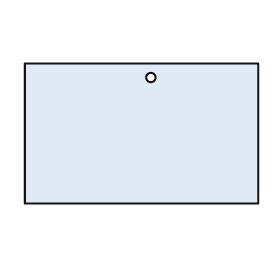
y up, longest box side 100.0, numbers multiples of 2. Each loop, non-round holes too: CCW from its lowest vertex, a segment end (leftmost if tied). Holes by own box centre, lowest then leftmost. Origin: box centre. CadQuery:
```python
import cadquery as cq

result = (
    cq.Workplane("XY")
    .moveTo(-50.0, -30.0)
    .lineTo(50.0, -30.0)
    .lineTo(50.0, 30.0)
    .lineTo(-50.0, 30.0)
    .close()
    .moveTo(4.0, 24.0)
    .circle(2.0)
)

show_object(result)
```